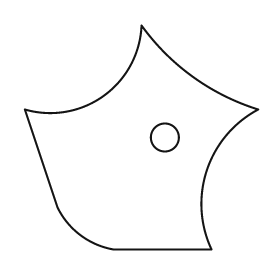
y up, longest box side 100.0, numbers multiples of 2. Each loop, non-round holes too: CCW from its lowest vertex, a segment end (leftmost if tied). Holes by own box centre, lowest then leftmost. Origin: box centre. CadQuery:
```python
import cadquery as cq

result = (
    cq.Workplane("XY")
    .moveTo(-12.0, -48.0)
    .lineTo(30.0, -48.0)
    .threePointArc((28.0, -14.0), (50.0, 12.0))
    .threePointArc((22.0, 26.0), (0.0, 48.0))
    .threePointArc((-16.0, 18.0), (-50.0, 12.0))
    .lineTo(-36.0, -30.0)
    .threePointArc((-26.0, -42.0), (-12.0, -48.0))
    .close()
    .moveTo(10.0, 0.0)
    .circle(6.0)
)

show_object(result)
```